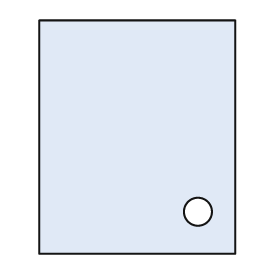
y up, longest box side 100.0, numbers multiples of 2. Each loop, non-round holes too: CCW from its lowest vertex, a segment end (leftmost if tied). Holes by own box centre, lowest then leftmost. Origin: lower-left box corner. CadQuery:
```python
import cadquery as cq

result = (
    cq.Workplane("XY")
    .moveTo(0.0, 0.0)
    .lineTo(84.0, 0.0)
    .lineTo(84.0, 100.0)
    .lineTo(0.0, 100.0)
    .close()
    .moveTo(68.0, 18.0)
    .circle(6.0)
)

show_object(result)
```